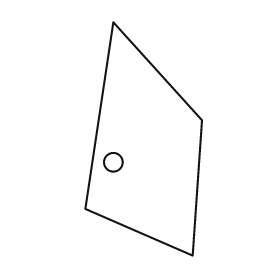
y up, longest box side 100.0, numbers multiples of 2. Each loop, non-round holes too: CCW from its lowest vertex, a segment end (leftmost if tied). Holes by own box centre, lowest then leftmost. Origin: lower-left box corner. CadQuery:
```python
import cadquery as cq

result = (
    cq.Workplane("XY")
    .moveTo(46.0, 0.0)
    .lineTo(50.0, 58.0)
    .lineTo(12.0, 100.0)
    .lineTo(0.0, 20.0)
    .close()
    .moveTo(12.0, 40.0)
    .circle(4.0)
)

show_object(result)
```